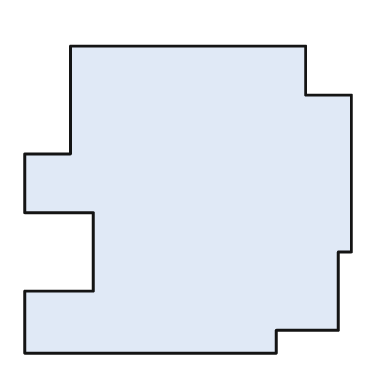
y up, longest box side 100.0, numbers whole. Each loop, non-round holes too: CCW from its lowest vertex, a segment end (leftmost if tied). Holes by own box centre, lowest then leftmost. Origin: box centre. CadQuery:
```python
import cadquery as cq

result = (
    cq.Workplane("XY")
    .moveTo(-50.0, -47.0)
    .lineTo(27.0, -47.0)
    .lineTo(27.0, -40.0)
    .lineTo(46.0, -40.0)
    .lineTo(46.0, -16.0)
    .lineTo(50.0, -16.0)
    .lineTo(50.0, 32.0)
    .lineTo(36.0, 32.0)
    .lineTo(36.0, 47.0)
    .lineTo(-36.0, 47.0)
    .lineTo(-36.0, 14.0)
    .lineTo(-50.0, 14.0)
    .lineTo(-50.0, -4.0)
    .lineTo(-29.0, -4.0)
    .lineTo(-29.0, -28.0)
    .lineTo(-50.0, -28.0)
    .close()
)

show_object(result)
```